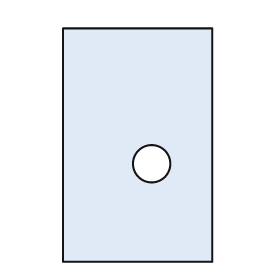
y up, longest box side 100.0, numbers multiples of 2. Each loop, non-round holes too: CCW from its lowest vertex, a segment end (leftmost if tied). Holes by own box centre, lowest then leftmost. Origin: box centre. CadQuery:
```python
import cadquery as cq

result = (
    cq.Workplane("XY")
    .moveTo(-32.0, -50.0)
    .lineTo(32.0, -50.0)
    .lineTo(32.0, 50.0)
    .lineTo(-32.0, 50.0)
    .close()
    .moveTo(6.0, -8.0)
    .circle(8.0)
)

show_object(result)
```